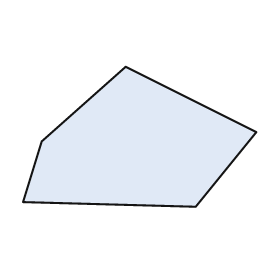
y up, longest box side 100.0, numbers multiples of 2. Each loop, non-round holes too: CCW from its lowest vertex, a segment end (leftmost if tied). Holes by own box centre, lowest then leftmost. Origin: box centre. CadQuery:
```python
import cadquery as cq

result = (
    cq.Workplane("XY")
    .moveTo(24.0, -30.0)
    .lineTo(50.0, 2.0)
    .lineTo(-6.0, 30.0)
    .lineTo(-42.0, -2.0)
    .lineTo(-50.0, -28.0)
    .close()
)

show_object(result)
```